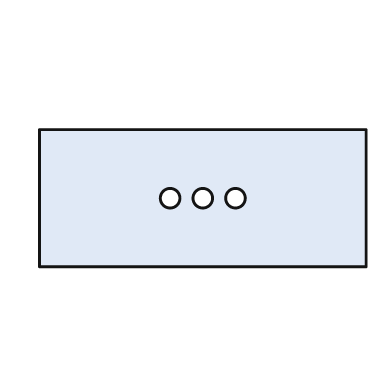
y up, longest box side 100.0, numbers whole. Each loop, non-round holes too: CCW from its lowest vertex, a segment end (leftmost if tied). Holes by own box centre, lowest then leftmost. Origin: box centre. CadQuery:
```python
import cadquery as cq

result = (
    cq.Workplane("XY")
    .moveTo(-50.0, -21.0)
    .lineTo(50.0, -21.0)
    .lineTo(50.0, 21.0)
    .lineTo(-50.0, 21.0)
    .close()
    .moveTo(-10.0, 0.0)
    .circle(3.0)
    .moveTo(0.0, 0.0)
    .circle(3.0)
    .moveTo(10.0, 0.0)
    .circle(3.0)
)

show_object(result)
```